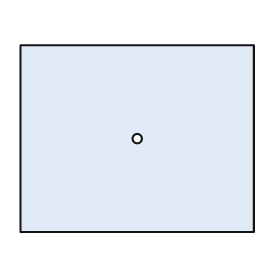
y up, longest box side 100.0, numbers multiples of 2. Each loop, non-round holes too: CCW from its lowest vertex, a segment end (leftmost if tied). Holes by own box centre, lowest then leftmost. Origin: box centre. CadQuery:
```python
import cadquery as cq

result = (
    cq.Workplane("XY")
    .moveTo(-50.0, -40.0)
    .lineTo(50.0, -40.0)
    .lineTo(50.0, 40.0)
    .lineTo(-50.0, 40.0)
    .close()
    .moveTo(0.0, 0.0)
    .circle(2.0)
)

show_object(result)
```